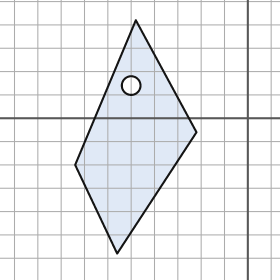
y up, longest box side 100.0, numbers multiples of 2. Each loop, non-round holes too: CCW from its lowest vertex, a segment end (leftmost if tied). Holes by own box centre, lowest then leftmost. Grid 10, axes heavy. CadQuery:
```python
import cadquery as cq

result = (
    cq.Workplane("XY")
    .moveTo(-56.0, -58.0)
    .lineTo(-22.0, -6.0)
    .lineTo(-48.0, 42.0)
    .lineTo(-74.0, -20.0)
    .close()
    .moveTo(-50.0, 14.0)
    .circle(4.0)
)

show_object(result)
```